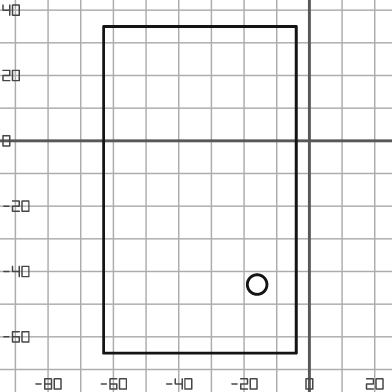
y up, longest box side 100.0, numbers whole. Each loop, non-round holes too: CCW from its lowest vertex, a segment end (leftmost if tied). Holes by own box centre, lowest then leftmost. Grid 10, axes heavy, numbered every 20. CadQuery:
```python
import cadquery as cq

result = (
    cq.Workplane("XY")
    .moveTo(-63.0, -65.0)
    .lineTo(-4.0, -65.0)
    .lineTo(-4.0, 35.0)
    .lineTo(-63.0, 35.0)
    .close()
    .moveTo(-16.0, -44.0)
    .circle(3.0)
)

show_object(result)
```